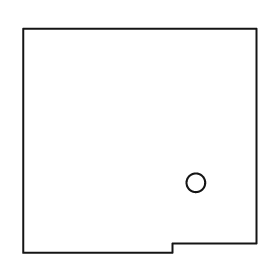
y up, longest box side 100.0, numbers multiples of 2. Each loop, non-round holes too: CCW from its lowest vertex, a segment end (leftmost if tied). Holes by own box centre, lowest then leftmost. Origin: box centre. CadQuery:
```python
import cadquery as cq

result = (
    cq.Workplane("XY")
    .moveTo(-50.0, -48.0)
    .lineTo(14.0, -48.0)
    .lineTo(14.0, -44.0)
    .lineTo(50.0, -44.0)
    .lineTo(50.0, 48.0)
    .lineTo(-50.0, 48.0)
    .close()
    .moveTo(24.0, -18.0)
    .circle(4.0)
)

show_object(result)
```